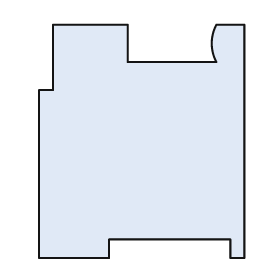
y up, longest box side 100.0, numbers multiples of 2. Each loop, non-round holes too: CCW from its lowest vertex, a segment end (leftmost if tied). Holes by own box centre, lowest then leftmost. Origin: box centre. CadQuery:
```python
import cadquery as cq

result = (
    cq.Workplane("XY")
    .moveTo(-44.0, -50.0)
    .lineTo(-14.0, -50.0)
    .lineTo(-14.0, -42.0)
    .lineTo(38.0, -42.0)
    .lineTo(38.0, -50.0)
    .lineTo(44.0, -50.0)
    .lineTo(44.0, 50.0)
    .lineTo(32.0, 50.0)
    .threePointArc((30.0, 42.0), (32.0, 34.0))
    .lineTo(-6.0, 34.0)
    .lineTo(-6.0, 50.0)
    .lineTo(-38.0, 50.0)
    .lineTo(-38.0, 22.0)
    .lineTo(-44.0, 22.0)
    .close()
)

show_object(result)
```